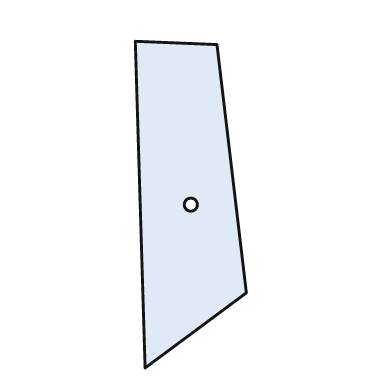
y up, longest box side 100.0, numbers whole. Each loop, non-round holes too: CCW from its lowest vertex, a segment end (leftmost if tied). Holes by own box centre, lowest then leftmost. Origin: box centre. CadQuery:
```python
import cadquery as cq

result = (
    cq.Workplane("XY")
    .moveTo(-14.0, -50.0)
    .lineTo(17.0, -27.0)
    .lineTo(8.0, 49.0)
    .lineTo(-17.0, 50.0)
    .close()
    .moveTo(0.0, 0.0)
    .circle(2.0)
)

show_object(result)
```